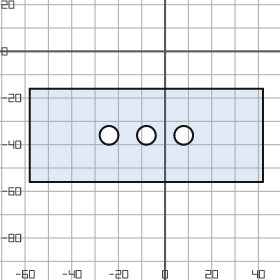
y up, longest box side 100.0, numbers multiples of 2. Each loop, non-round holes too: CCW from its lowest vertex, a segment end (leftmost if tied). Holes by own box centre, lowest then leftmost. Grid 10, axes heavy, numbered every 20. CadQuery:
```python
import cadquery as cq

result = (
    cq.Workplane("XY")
    .moveTo(-58.0, -56.0)
    .lineTo(42.0, -56.0)
    .lineTo(42.0, -16.0)
    .lineTo(-58.0, -16.0)
    .close()
    .moveTo(-24.0, -36.0)
    .circle(4.0)
    .moveTo(-8.0, -36.0)
    .circle(4.0)
    .moveTo(8.0, -36.0)
    .circle(4.0)
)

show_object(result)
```